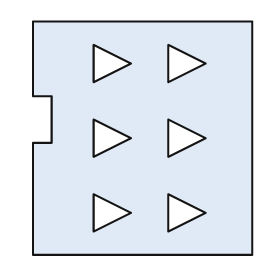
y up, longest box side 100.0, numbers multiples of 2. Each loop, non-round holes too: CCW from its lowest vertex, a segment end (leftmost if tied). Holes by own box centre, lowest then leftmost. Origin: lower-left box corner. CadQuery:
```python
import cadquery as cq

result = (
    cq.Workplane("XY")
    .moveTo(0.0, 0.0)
    .lineTo(94.0, 0.0)
    .lineTo(94.0, 100.0)
    .lineTo(0.0, 100.0)
    .lineTo(0.0, 68.0)
    .lineTo(8.0, 68.0)
    .lineTo(8.0, 48.0)
    .lineTo(0.0, 48.0)
    .close()
    .moveTo(26.0, 10.0)
    .lineTo(42.0, 18.0)
    .lineTo(26.0, 26.0)
    .close()
    .moveTo(58.0, 10.0)
    .lineTo(74.0, 18.0)
    .lineTo(58.0, 26.0)
    .close()
    .moveTo(26.0, 42.0)
    .lineTo(42.0, 50.0)
    .lineTo(26.0, 58.0)
    .close()
    .moveTo(58.0, 42.0)
    .lineTo(74.0, 50.0)
    .lineTo(58.0, 58.0)
    .close()
    .moveTo(26.0, 74.0)
    .lineTo(42.0, 82.0)
    .lineTo(26.0, 90.0)
    .close()
    .moveTo(58.0, 74.0)
    .lineTo(74.0, 82.0)
    .lineTo(58.0, 90.0)
    .close()
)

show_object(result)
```